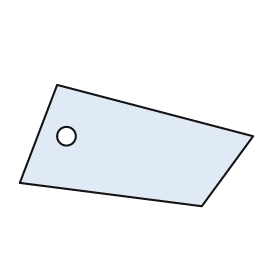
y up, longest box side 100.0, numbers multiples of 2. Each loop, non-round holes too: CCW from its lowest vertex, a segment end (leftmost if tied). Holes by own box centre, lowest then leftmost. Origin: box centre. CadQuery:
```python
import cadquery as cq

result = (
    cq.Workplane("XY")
    .moveTo(28.0, -26.0)
    .lineTo(50.0, 4.0)
    .lineTo(-34.0, 26.0)
    .lineTo(-50.0, -16.0)
    .close()
    .moveTo(-30.0, 4.0)
    .circle(4.0)
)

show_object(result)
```